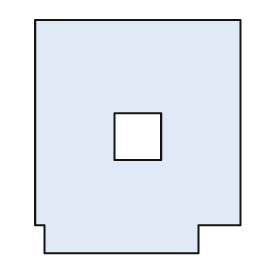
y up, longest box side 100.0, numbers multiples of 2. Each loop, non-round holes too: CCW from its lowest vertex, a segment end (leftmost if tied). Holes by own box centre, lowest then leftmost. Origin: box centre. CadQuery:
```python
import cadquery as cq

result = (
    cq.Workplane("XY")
    .moveTo(-40.0, -50.0)
    .lineTo(26.0, -50.0)
    .lineTo(26.0, -38.0)
    .lineTo(44.0, -38.0)
    .lineTo(44.0, 50.0)
    .lineTo(-44.0, 50.0)
    .lineTo(-44.0, -38.0)
    .lineTo(-40.0, -38.0)
    .close()
    .moveTo(-10.0, -10.0)
    .lineTo(10.0, -10.0)
    .lineTo(10.0, 10.0)
    .lineTo(-10.0, 10.0)
    .close()
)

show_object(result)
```